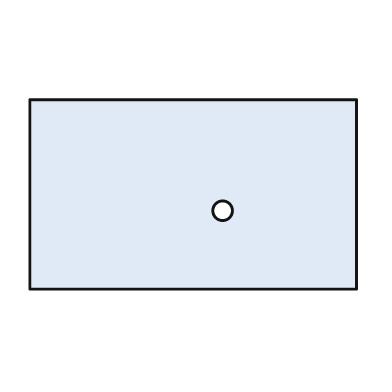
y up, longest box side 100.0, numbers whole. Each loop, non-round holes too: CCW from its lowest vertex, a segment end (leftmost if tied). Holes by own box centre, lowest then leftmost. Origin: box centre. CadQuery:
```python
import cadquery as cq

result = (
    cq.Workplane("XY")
    .moveTo(-50.0, -29.0)
    .lineTo(50.0, -29.0)
    .lineTo(50.0, 29.0)
    .lineTo(-50.0, 29.0)
    .close()
    .moveTo(9.0, -5.0)
    .circle(3.0)
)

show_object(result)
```